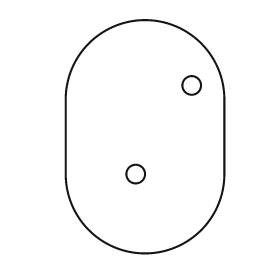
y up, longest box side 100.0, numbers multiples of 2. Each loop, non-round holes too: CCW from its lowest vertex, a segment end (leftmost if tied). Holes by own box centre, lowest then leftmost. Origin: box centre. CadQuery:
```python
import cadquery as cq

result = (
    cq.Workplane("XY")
    .moveTo(-34.0, -16.0)
    .threePointArc((0.0, -50.0), (34.0, -16.0))
    .lineTo(34.0, 16.0)
    .threePointArc((0.0, 50.0), (-34.0, 16.0))
    .close()
    .moveTo(-4.0, -16.0)
    .circle(4.0)
    .moveTo(20.0, 22.0)
    .circle(4.0)
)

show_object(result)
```